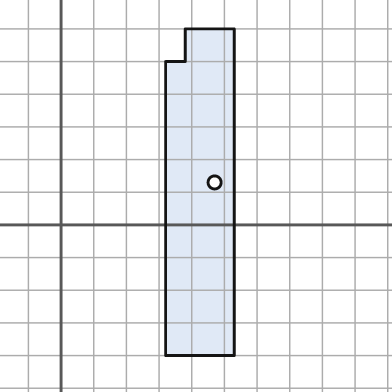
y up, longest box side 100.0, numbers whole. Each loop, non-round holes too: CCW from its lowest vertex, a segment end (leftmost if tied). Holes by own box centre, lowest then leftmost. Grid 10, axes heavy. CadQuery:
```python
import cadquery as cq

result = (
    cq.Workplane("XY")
    .moveTo(32.0, -40.0)
    .lineTo(53.0, -40.0)
    .lineTo(53.0, 60.0)
    .lineTo(38.0, 60.0)
    .lineTo(38.0, 50.0)
    .lineTo(32.0, 50.0)
    .close()
    .moveTo(47.0, 13.0)
    .circle(2.0)
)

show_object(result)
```